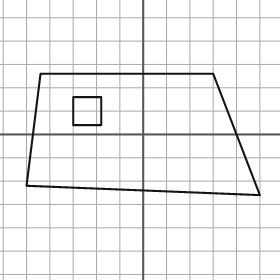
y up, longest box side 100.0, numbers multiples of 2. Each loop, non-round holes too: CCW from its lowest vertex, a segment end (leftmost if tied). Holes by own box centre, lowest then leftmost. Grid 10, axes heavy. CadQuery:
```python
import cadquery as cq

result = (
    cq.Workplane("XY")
    .moveTo(50.0, -26.0)
    .lineTo(30.0, 26.0)
    .lineTo(-44.0, 26.0)
    .lineTo(-50.0, -22.0)
    .close()
    .moveTo(-30.0, 4.0)
    .lineTo(-18.0, 4.0)
    .lineTo(-18.0, 16.0)
    .lineTo(-30.0, 16.0)
    .close()
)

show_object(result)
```